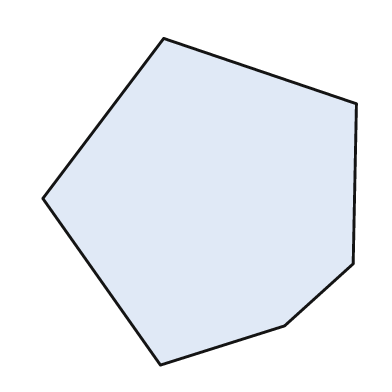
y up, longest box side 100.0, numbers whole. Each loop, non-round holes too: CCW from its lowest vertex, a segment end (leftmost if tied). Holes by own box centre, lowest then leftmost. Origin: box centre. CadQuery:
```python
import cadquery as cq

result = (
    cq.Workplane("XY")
    .moveTo(-12.0, -50.0)
    .lineTo(26.0, -38.0)
    .lineTo(47.0, -19.0)
    .lineTo(48.0, 30.0)
    .lineTo(-11.0, 50.0)
    .lineTo(-48.0, 1.0)
    .close()
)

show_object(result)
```